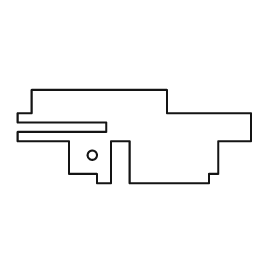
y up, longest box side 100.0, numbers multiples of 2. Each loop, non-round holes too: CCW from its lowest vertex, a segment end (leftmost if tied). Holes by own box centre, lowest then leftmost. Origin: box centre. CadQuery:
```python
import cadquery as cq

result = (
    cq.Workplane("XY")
    .moveTo(-16.0, -20.0)
    .lineTo(-10.0, -20.0)
    .lineTo(-10.0, -2.0)
    .lineTo(-2.0, -2.0)
    .lineTo(-2.0, -20.0)
    .lineTo(32.0, -20.0)
    .lineTo(32.0, -16.0)
    .lineTo(36.0, -16.0)
    .lineTo(36.0, -2.0)
    .lineTo(50.0, -2.0)
    .lineTo(50.0, 10.0)
    .lineTo(14.0, 10.0)
    .lineTo(14.0, 20.0)
    .lineTo(-44.0, 20.0)
    .lineTo(-44.0, 10.0)
    .lineTo(-50.0, 10.0)
    .lineTo(-50.0, 6.0)
    .lineTo(-12.0, 6.0)
    .lineTo(-12.0, 2.0)
    .lineTo(-50.0, 2.0)
    .lineTo(-50.0, -2.0)
    .lineTo(-28.0, -2.0)
    .lineTo(-28.0, -16.0)
    .lineTo(-16.0, -16.0)
    .close()
    .moveTo(-18.0, -8.0)
    .circle(2.0)
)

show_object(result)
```